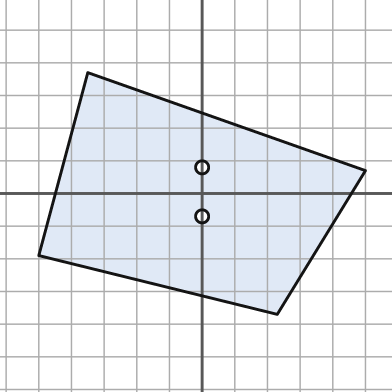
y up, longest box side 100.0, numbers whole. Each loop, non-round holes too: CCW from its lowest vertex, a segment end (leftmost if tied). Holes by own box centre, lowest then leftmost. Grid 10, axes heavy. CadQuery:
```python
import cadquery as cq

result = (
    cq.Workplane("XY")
    .moveTo(23.0, -37.0)
    .lineTo(50.0, 7.0)
    .lineTo(-35.0, 37.0)
    .lineTo(-50.0, -19.0)
    .close()
    .moveTo(0.0, -7.0)
    .circle(2.0)
    .moveTo(0.0, 8.0)
    .circle(2.0)
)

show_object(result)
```